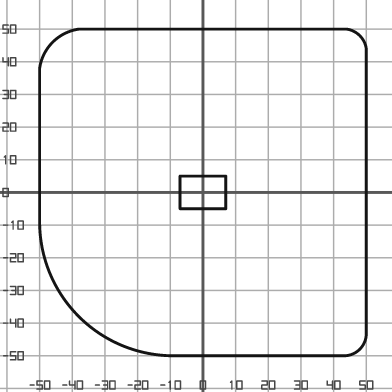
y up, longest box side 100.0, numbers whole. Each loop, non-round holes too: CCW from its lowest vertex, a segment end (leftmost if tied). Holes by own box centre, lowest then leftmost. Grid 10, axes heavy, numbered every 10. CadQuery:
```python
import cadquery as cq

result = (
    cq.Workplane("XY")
    .moveTo(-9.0, -50.0)
    .lineTo(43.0, -50.0)
    .threePointArc((48.0, -48.0), (50.0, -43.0))
    .lineTo(50.0, 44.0)
    .threePointArc((48.0, 48.0), (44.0, 50.0))
    .lineTo(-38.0, 50.0)
    .threePointArc((-46.0, 46.0), (-50.0, 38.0))
    .lineTo(-50.0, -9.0)
    .threePointArc((-38.0, -38.0), (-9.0, -50.0))
    .close()
    .moveTo(-7.0, -5.0)
    .lineTo(7.0, -5.0)
    .lineTo(7.0, 5.0)
    .lineTo(-7.0, 5.0)
    .close()
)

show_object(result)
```